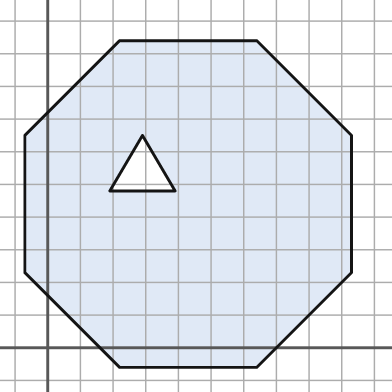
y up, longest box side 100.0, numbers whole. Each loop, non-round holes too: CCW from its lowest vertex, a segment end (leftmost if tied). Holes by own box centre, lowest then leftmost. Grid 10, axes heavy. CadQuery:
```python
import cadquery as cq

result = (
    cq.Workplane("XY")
    .moveTo(22.0, -6.0)
    .lineTo(64.0, -6.0)
    .lineTo(93.0, 23.0)
    .lineTo(93.0, 65.0)
    .lineTo(64.0, 94.0)
    .lineTo(22.0, 94.0)
    .lineTo(-7.0, 65.0)
    .lineTo(-7.0, 23.0)
    .close()
    .moveTo(19.0, 48.0)
    .lineTo(39.0, 48.0)
    .lineTo(29.0, 65.0)
    .close()
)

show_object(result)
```